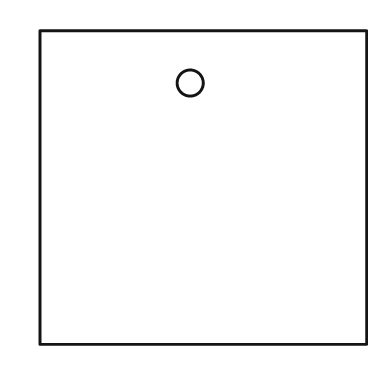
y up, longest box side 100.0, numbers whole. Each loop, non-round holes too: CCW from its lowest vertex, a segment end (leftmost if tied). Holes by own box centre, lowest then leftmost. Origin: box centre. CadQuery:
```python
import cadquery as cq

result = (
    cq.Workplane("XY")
    .moveTo(-50.0, -48.0)
    .lineTo(50.0, -48.0)
    .lineTo(50.0, 48.0)
    .lineTo(-50.0, 48.0)
    .close()
    .moveTo(-4.0, 32.0)
    .circle(4.0)
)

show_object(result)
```